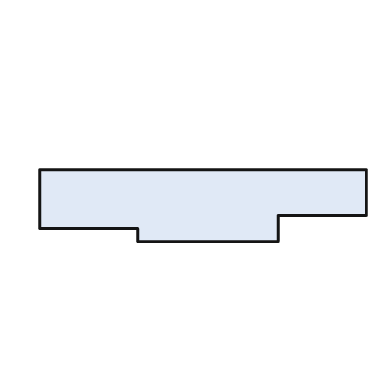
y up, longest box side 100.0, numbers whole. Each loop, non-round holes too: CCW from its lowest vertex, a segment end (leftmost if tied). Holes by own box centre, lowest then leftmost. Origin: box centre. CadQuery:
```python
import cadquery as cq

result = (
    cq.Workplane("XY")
    .moveTo(-20.0, -11.0)
    .lineTo(23.0, -11.0)
    .lineTo(23.0, -3.0)
    .lineTo(50.0, -3.0)
    .lineTo(50.0, 11.0)
    .lineTo(-50.0, 11.0)
    .lineTo(-50.0, -7.0)
    .lineTo(-20.0, -7.0)
    .close()
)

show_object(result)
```